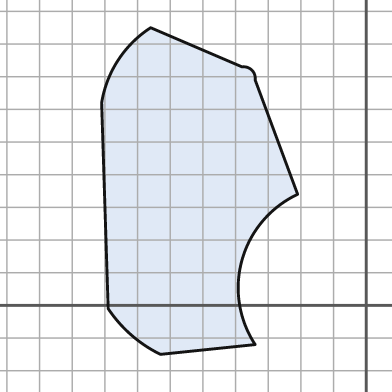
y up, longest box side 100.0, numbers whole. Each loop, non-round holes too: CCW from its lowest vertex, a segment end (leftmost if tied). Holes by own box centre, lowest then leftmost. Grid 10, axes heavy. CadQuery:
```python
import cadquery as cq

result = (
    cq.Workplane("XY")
    .moveTo(-63.0, -15.0)
    .lineTo(-34.0, -12.0)
    .threePointArc((-38.0, 14.0), (-21.0, 34.0))
    .lineTo(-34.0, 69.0)
    .threePointArc((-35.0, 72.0), (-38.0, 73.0))
    .lineTo(-66.0, 85.0)
    .threePointArc((-76.0, 75.0), (-81.0, 62.0))
    .lineTo(-79.0, -1.0)
    .threePointArc((-72.0, -9.0), (-63.0, -15.0))
    .close()
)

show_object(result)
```